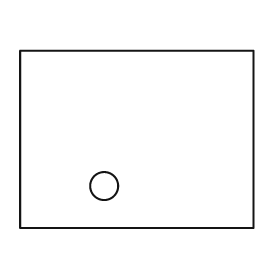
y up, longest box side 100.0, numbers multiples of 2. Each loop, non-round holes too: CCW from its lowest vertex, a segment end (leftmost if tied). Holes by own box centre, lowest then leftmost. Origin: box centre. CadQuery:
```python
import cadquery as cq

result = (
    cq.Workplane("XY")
    .moveTo(-50.0, -38.0)
    .lineTo(50.0, -38.0)
    .lineTo(50.0, 38.0)
    .lineTo(-50.0, 38.0)
    .close()
    .moveTo(-14.0, -20.0)
    .circle(6.0)
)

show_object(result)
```